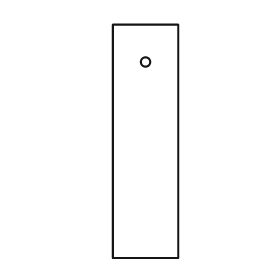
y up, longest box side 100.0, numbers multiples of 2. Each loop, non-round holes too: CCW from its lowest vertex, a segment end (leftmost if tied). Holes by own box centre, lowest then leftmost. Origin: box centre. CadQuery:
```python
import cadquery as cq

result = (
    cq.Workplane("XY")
    .moveTo(-14.0, -50.0)
    .lineTo(14.0, -50.0)
    .lineTo(14.0, 50.0)
    .lineTo(-14.0, 50.0)
    .close()
    .moveTo(0.0, 34.0)
    .circle(2.0)
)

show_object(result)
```